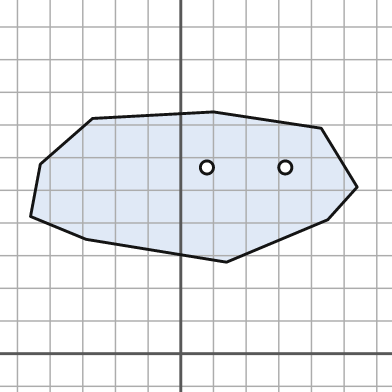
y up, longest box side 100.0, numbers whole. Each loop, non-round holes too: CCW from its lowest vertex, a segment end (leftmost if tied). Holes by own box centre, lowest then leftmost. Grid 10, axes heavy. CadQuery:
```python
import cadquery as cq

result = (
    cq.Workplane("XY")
    .moveTo(14.0, 28.0)
    .lineTo(45.0, 41.0)
    .lineTo(54.0, 51.0)
    .lineTo(43.0, 69.0)
    .lineTo(10.0, 74.0)
    .lineTo(-27.0, 72.0)
    .lineTo(-43.0, 58.0)
    .lineTo(-46.0, 42.0)
    .lineTo(-29.0, 35.0)
    .close()
    .moveTo(8.0, 57.0)
    .circle(2.0)
    .moveTo(32.0, 57.0)
    .circle(2.0)
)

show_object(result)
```